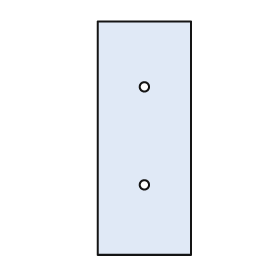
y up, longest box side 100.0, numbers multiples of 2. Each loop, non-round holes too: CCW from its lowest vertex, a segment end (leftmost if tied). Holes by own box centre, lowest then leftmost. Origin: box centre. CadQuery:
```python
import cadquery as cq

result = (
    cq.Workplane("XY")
    .moveTo(-20.0, -50.0)
    .lineTo(20.0, -50.0)
    .lineTo(20.0, 50.0)
    .lineTo(-20.0, 50.0)
    .close()
    .moveTo(0.0, -20.0)
    .circle(2.0)
    .moveTo(0.0, 22.0)
    .circle(2.0)
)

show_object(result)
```